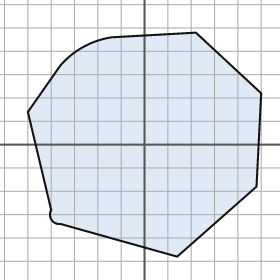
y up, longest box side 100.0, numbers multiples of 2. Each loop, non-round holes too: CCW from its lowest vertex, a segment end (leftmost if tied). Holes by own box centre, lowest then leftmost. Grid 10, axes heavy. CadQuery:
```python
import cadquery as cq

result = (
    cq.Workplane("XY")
    .moveTo(14.0, -48.0)
    .lineTo(48.0, -18.0)
    .lineTo(50.0, 22.0)
    .lineTo(22.0, 48.0)
    .lineTo(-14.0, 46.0)
    .threePointArc((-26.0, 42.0), (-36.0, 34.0))
    .lineTo(-50.0, 14.0)
    .lineTo(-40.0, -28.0)
    .threePointArc((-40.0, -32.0), (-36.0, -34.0))
    .close()
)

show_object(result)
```